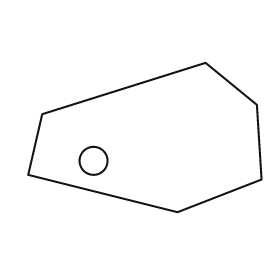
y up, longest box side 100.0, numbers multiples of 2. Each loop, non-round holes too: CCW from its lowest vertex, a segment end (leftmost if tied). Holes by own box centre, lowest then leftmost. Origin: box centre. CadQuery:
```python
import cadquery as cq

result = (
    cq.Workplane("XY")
    .moveTo(14.0, -32.0)
    .lineTo(50.0, -18.0)
    .lineTo(48.0, 14.0)
    .lineTo(26.0, 32.0)
    .lineTo(-44.0, 10.0)
    .lineTo(-50.0, -16.0)
    .close()
    .moveTo(-22.0, -10.0)
    .circle(6.0)
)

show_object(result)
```